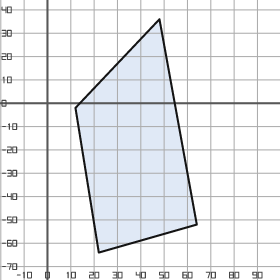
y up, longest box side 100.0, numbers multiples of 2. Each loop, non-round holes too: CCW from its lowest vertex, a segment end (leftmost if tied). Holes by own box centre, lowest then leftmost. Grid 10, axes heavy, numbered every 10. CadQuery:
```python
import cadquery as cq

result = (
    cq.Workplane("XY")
    .moveTo(22.0, -64.0)
    .lineTo(64.0, -52.0)
    .lineTo(48.0, 36.0)
    .lineTo(12.0, -2.0)
    .close()
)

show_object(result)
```